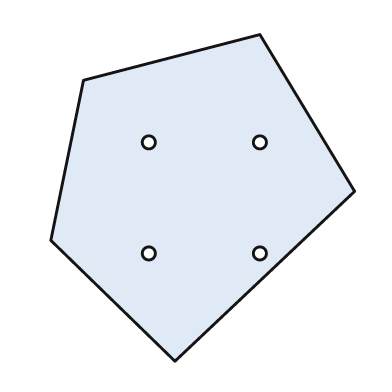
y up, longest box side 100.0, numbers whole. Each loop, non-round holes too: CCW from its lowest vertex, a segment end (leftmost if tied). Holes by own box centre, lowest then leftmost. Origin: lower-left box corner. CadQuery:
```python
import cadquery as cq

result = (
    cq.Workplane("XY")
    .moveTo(38.0, 0.0)
    .lineTo(93.0, 52.0)
    .lineTo(64.0, 100.0)
    .lineTo(10.0, 86.0)
    .lineTo(0.0, 37.0)
    .close()
    .moveTo(30.0, 33.0)
    .circle(2.0)
    .moveTo(64.0, 33.0)
    .circle(2.0)
    .moveTo(30.0, 67.0)
    .circle(2.0)
    .moveTo(64.0, 67.0)
    .circle(2.0)
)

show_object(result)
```